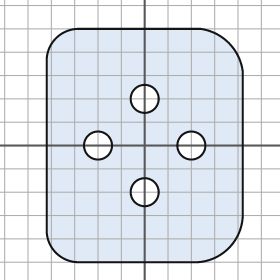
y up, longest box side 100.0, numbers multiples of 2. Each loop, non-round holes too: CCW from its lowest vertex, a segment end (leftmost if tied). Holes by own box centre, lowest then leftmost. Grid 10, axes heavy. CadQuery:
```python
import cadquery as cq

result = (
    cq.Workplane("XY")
    .moveTo(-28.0, -50.0)
    .lineTo(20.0, -50.0)
    .threePointArc((36.0, -44.0), (42.0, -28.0))
    .lineTo(42.0, 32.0)
    .threePointArc((36.0, 44.0), (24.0, 50.0))
    .lineTo(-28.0, 50.0)
    .threePointArc((-38.0, 46.0), (-42.0, 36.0))
    .lineTo(-42.0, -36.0)
    .threePointArc((-38.0, -46.0), (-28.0, -50.0))
    .close()
    .moveTo(0.0, -20.0)
    .circle(6.0)
    .moveTo(-20.0, 0.0)
    .circle(6.0)
    .moveTo(20.0, 0.0)
    .circle(6.0)
    .moveTo(0.0, 20.0)
    .circle(6.0)
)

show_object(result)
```